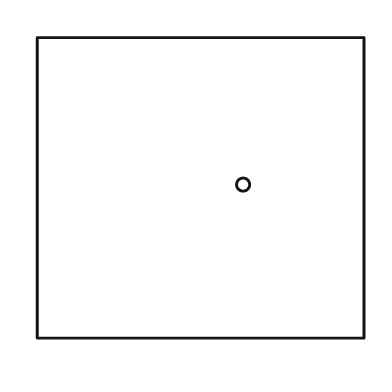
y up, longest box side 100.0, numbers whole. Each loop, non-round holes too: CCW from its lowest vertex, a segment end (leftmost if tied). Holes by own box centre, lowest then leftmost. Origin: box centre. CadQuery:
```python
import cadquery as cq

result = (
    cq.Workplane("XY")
    .moveTo(-50.0, -46.0)
    .lineTo(50.0, -46.0)
    .lineTo(50.0, 46.0)
    .lineTo(-50.0, 46.0)
    .close()
    .moveTo(13.0, 1.0)
    .circle(2.0)
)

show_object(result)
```